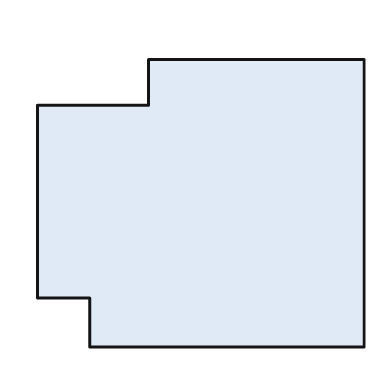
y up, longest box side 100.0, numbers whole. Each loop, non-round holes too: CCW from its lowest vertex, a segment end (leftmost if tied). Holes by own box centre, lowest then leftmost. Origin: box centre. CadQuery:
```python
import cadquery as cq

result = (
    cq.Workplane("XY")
    .moveTo(-34.0, -44.0)
    .lineTo(50.0, -44.0)
    .lineTo(50.0, 44.0)
    .lineTo(-16.0, 44.0)
    .lineTo(-16.0, 30.0)
    .lineTo(-50.0, 30.0)
    .lineTo(-50.0, -29.0)
    .lineTo(-34.0, -29.0)
    .close()
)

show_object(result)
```